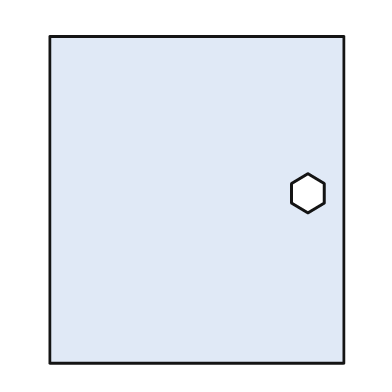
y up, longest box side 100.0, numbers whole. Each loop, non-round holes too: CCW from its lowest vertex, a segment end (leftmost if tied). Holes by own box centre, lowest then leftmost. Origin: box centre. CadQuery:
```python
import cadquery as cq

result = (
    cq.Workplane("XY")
    .moveTo(-45.0, -50.0)
    .lineTo(45.0, -50.0)
    .lineTo(45.0, 50.0)
    .lineTo(-45.0, 50.0)
    .close()
    .moveTo(34.0, -4.0)
    .lineTo(39.0, -1.0)
    .lineTo(39.0, 5.0)
    .lineTo(34.0, 8.0)
    .lineTo(29.0, 5.0)
    .lineTo(29.0, -1.0)
    .close()
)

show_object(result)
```